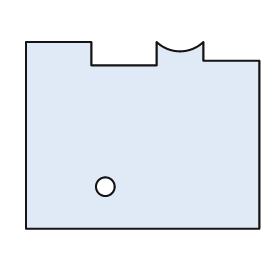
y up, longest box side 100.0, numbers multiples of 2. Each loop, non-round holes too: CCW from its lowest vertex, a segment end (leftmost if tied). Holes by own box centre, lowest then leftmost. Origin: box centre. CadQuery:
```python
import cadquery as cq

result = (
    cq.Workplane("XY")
    .moveTo(-50.0, -40.0)
    .lineTo(50.0, -40.0)
    .lineTo(50.0, 32.0)
    .lineTo(26.0, 32.0)
    .lineTo(26.0, 40.0)
    .threePointArc((16.0, 36.0), (6.0, 40.0))
    .lineTo(6.0, 30.0)
    .lineTo(-22.0, 30.0)
    .lineTo(-22.0, 40.0)
    .lineTo(-50.0, 40.0)
    .close()
    .moveTo(-16.0, -22.0)
    .circle(4.0)
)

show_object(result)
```